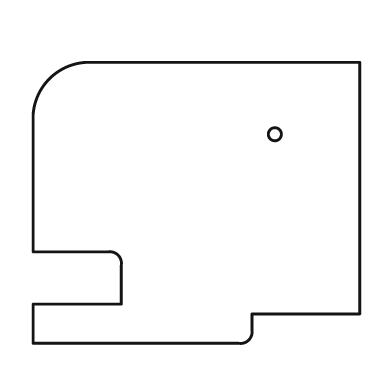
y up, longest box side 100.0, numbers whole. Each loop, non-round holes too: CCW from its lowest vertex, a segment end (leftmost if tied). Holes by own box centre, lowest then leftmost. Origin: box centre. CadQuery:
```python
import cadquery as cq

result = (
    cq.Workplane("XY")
    .moveTo(-50.0, -43.0)
    .lineTo(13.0, -43.0)
    .threePointArc((16.0, -42.0), (17.0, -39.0))
    .lineTo(17.0, -34.0)
    .lineTo(50.0, -34.0)
    .lineTo(50.0, 43.0)
    .lineTo(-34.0, 43.0)
    .threePointArc((-45.0, 38.0), (-50.0, 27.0))
    .lineTo(-50.0, -15.0)
    .lineTo(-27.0, -15.0)
    .threePointArc((-24.0, -16.0), (-23.0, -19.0))
    .lineTo(-23.0, -31.0)
    .lineTo(-50.0, -31.0)
    .close()
    .moveTo(24.0, 21.0)
    .circle(2.0)
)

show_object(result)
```